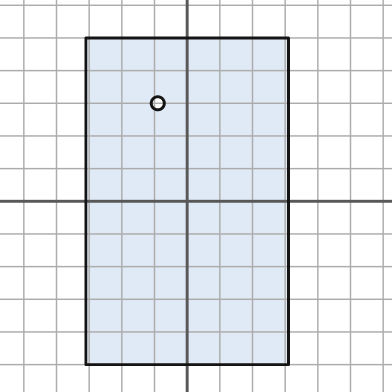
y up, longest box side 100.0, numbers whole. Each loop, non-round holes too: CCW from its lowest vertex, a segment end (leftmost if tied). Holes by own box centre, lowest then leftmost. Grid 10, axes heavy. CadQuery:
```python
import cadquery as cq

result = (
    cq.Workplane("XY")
    .moveTo(-31.0, -50.0)
    .lineTo(31.0, -50.0)
    .lineTo(31.0, 50.0)
    .lineTo(-31.0, 50.0)
    .close()
    .moveTo(-9.0, 30.0)
    .circle(2.0)
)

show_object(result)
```